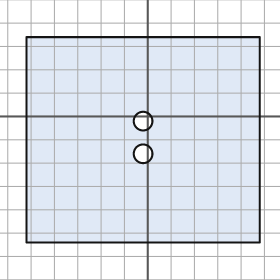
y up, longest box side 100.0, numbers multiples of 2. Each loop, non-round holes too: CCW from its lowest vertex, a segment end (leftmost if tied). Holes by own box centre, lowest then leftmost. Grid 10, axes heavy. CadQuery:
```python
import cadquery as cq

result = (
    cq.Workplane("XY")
    .moveTo(-52.0, -54.0)
    .lineTo(48.0, -54.0)
    .lineTo(48.0, 34.0)
    .lineTo(-52.0, 34.0)
    .close()
    .moveTo(-2.0, -16.0)
    .circle(4.0)
    .moveTo(-2.0, -2.0)
    .circle(4.0)
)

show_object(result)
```